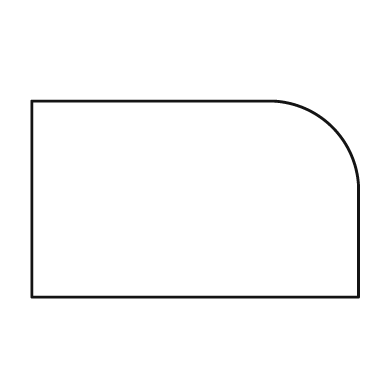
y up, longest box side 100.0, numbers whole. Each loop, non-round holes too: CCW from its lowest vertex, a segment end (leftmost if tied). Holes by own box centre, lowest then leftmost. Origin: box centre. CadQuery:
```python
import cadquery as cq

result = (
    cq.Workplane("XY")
    .moveTo(-50.0, -30.0)
    .lineTo(50.0, -30.0)
    .lineTo(50.0, 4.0)
    .threePointArc((42.0, 22.0), (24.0, 30.0))
    .lineTo(-50.0, 30.0)
    .close()
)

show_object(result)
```